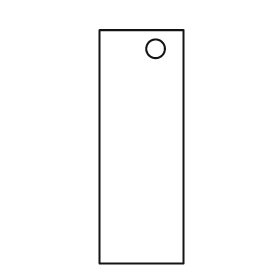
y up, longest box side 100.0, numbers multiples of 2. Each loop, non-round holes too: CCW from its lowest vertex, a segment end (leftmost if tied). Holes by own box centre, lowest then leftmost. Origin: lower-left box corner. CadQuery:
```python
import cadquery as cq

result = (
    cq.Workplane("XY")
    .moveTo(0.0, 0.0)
    .lineTo(36.0, 0.0)
    .lineTo(36.0, 100.0)
    .lineTo(0.0, 100.0)
    .close()
    .moveTo(24.0, 92.0)
    .circle(4.0)
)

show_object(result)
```